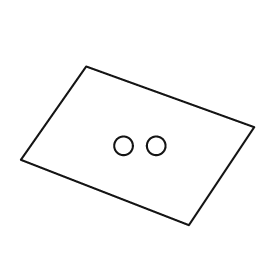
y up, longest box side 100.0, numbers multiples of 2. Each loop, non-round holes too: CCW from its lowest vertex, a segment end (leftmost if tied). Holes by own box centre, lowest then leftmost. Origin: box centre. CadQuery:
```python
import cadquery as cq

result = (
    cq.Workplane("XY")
    .moveTo(22.0, -34.0)
    .lineTo(50.0, 8.0)
    .lineTo(-22.0, 34.0)
    .lineTo(-50.0, -6.0)
    .close()
    .moveTo(-6.0, 0.0)
    .circle(4.0)
    .moveTo(8.0, 0.0)
    .circle(4.0)
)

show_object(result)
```